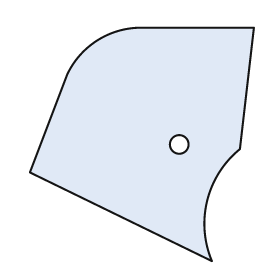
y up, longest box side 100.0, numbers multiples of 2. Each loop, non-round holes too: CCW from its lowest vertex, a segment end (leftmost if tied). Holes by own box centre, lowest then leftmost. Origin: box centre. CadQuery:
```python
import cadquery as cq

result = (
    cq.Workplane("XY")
    .moveTo(30.0, -50.0)
    .threePointArc((28.0, -24.0), (42.0, -2.0))
    .lineTo(48.0, 50.0)
    .lineTo(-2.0, 50.0)
    .threePointArc((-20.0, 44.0), (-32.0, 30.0))
    .lineTo(-48.0, -12.0)
    .close()
    .moveTo(16.0, 0.0)
    .circle(4.0)
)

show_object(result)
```